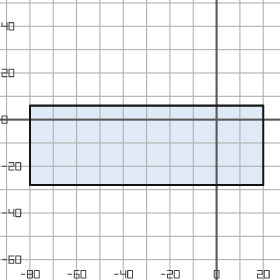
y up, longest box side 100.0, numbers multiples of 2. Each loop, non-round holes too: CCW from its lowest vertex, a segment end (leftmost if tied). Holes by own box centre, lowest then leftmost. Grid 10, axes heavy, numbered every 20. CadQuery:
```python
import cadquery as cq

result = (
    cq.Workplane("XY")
    .moveTo(-80.0, -28.0)
    .lineTo(20.0, -28.0)
    .lineTo(20.0, 6.0)
    .lineTo(-80.0, 6.0)
    .close()
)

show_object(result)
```